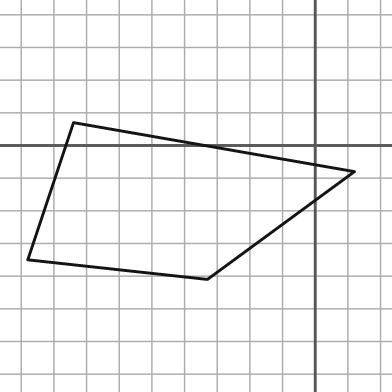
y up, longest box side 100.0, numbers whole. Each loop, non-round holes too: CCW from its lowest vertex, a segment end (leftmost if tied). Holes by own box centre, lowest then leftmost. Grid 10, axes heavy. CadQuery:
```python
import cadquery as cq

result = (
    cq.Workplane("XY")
    .moveTo(-33.0, -41.0)
    .lineTo(12.0, -8.0)
    .lineTo(-74.0, 7.0)
    .lineTo(-88.0, -35.0)
    .close()
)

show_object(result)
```